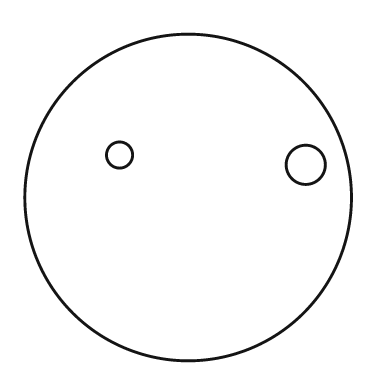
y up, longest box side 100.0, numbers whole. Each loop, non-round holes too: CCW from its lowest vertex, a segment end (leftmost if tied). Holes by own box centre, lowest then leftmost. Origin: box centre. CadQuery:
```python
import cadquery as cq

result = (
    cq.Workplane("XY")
    .moveTo(0.0, 0.0)
    .circle(50.0)
    .moveTo(36.0, 10.0)
    .circle(6.0)
    .moveTo(-21.0, 13.0)
    .circle(4.0)
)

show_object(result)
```